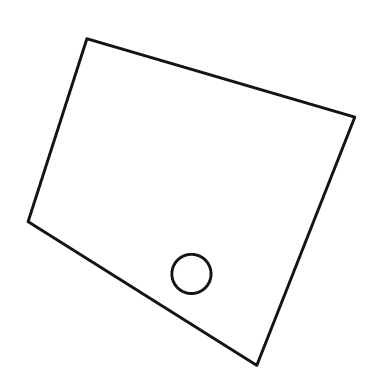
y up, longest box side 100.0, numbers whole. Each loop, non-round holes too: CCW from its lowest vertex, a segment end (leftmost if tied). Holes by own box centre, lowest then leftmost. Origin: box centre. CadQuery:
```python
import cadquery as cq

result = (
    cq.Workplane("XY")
    .moveTo(20.0, -50.0)
    .lineTo(50.0, 26.0)
    .lineTo(-32.0, 50.0)
    .lineTo(-50.0, -6.0)
    .close()
    .moveTo(0.0, -22.0)
    .circle(6.0)
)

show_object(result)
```